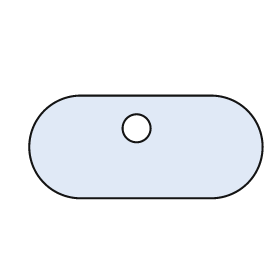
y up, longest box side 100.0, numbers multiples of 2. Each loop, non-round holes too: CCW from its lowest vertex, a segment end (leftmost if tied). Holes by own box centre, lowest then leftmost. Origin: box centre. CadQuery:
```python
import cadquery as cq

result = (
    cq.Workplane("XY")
    .moveTo(-28.0, -22.0)
    .lineTo(28.0, -22.0)
    .threePointArc((50.0, 0.0), (28.0, 22.0))
    .lineTo(-28.0, 22.0)
    .threePointArc((-50.0, 0.0), (-28.0, -22.0))
    .close()
    .moveTo(-4.0, 8.0)
    .circle(6.0)
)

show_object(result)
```